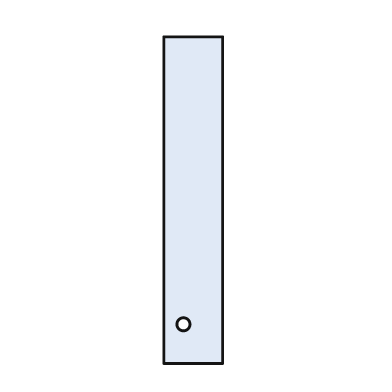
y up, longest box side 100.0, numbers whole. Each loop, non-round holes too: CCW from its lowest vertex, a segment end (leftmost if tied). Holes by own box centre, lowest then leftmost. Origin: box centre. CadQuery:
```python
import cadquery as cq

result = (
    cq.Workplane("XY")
    .moveTo(-9.0, -50.0)
    .lineTo(9.0, -50.0)
    .lineTo(9.0, 50.0)
    .lineTo(-9.0, 50.0)
    .close()
    .moveTo(-3.0, -38.0)
    .circle(2.0)
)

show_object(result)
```